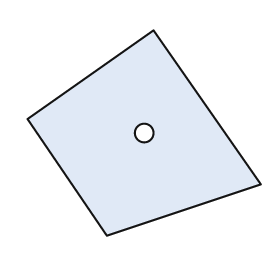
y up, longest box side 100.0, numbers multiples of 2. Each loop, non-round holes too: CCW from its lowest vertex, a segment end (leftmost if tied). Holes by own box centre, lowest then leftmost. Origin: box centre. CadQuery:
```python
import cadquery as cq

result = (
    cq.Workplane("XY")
    .moveTo(-16.0, -44.0)
    .lineTo(50.0, -22.0)
    .lineTo(4.0, 44.0)
    .lineTo(-50.0, 6.0)
    .close()
    .moveTo(0.0, 0.0)
    .circle(4.0)
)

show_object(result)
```